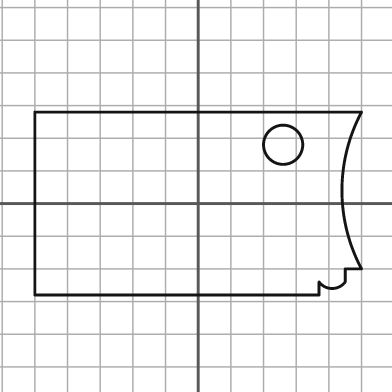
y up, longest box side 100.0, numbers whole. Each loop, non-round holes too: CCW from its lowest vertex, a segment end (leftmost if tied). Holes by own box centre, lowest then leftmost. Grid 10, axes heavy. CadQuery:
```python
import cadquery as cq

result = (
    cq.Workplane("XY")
    .moveTo(-50.0, -28.0)
    .lineTo(37.0, -28.0)
    .lineTo(37.0, -24.0)
    .threePointArc((41.0, -26.0), (45.0, -24.0))
    .lineTo(45.0, -20.0)
    .lineTo(50.0, -20.0)
    .threePointArc((44.0, 4.0), (50.0, 28.0))
    .lineTo(-50.0, 28.0)
    .close()
    .moveTo(26.0, 18.0)
    .circle(6.0)
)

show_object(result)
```